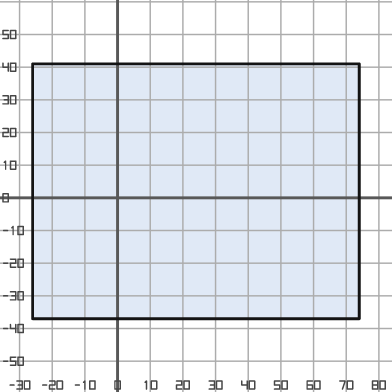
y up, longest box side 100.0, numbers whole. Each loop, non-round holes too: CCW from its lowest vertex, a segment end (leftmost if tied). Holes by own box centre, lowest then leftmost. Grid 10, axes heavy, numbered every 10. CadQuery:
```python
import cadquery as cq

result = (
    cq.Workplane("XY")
    .moveTo(-26.0, -37.0)
    .lineTo(74.0, -37.0)
    .lineTo(74.0, 41.0)
    .lineTo(-26.0, 41.0)
    .close()
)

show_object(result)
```